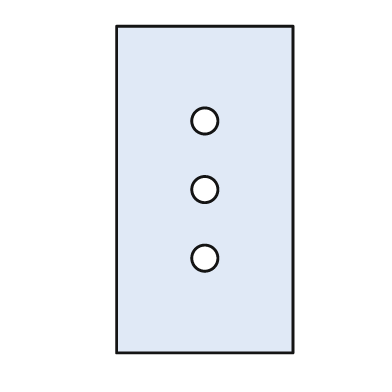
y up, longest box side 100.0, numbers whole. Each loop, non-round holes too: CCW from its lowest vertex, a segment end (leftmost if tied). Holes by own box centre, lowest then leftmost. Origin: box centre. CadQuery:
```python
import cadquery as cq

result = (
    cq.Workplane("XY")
    .moveTo(-27.0, -50.0)
    .lineTo(27.0, -50.0)
    .lineTo(27.0, 50.0)
    .lineTo(-27.0, 50.0)
    .close()
    .moveTo(0.0, -21.0)
    .circle(4.0)
    .moveTo(0.0, 0.0)
    .circle(4.0)
    .moveTo(0.0, 21.0)
    .circle(4.0)
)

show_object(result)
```